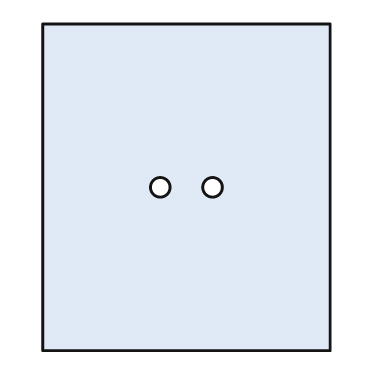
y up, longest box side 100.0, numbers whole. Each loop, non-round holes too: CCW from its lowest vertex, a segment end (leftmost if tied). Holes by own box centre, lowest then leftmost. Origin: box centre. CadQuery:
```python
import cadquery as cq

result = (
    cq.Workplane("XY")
    .moveTo(-44.0, -50.0)
    .lineTo(44.0, -50.0)
    .lineTo(44.0, 50.0)
    .lineTo(-44.0, 50.0)
    .close()
    .moveTo(-8.0, 0.0)
    .circle(3.0)
    .moveTo(8.0, 0.0)
    .circle(3.0)
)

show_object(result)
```